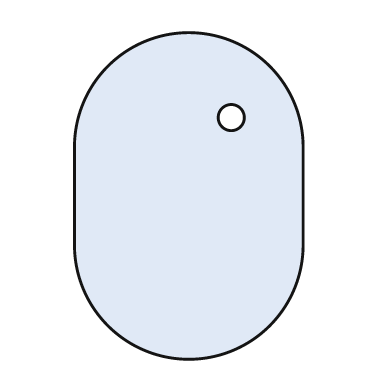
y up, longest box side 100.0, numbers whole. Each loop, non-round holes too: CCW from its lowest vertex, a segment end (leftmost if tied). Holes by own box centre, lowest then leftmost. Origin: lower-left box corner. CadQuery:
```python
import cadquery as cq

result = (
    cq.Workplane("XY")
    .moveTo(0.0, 35.0)
    .threePointArc((35.0, 0.0), (70.0, 35.0))
    .lineTo(70.0, 65.0)
    .threePointArc((35.0, 100.0), (0.0, 65.0))
    .close()
    .moveTo(48.0, 74.0)
    .circle(4.0)
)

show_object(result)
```